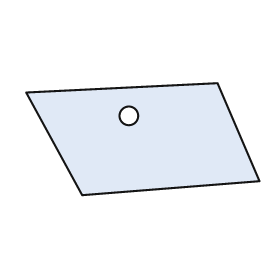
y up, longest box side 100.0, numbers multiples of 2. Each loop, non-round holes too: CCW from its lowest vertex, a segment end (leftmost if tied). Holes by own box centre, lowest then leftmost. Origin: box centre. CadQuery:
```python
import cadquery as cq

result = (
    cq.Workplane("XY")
    .moveTo(-26.0, -24.0)
    .lineTo(50.0, -18.0)
    .lineTo(32.0, 24.0)
    .lineTo(-50.0, 20.0)
    .close()
    .moveTo(-6.0, 10.0)
    .circle(4.0)
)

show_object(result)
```